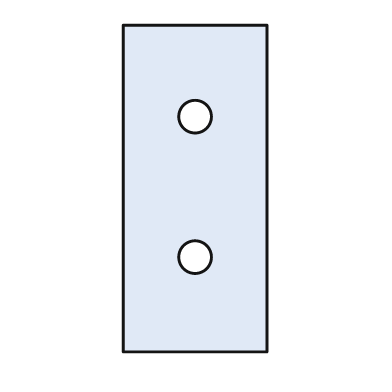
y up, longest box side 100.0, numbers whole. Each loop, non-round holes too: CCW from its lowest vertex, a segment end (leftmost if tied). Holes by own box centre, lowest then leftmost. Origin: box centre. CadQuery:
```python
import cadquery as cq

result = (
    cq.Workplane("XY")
    .moveTo(-22.0, -50.0)
    .lineTo(22.0, -50.0)
    .lineTo(22.0, 50.0)
    .lineTo(-22.0, 50.0)
    .close()
    .moveTo(0.0, -21.0)
    .circle(5.0)
    .moveTo(0.0, 22.0)
    .circle(5.0)
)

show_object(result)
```